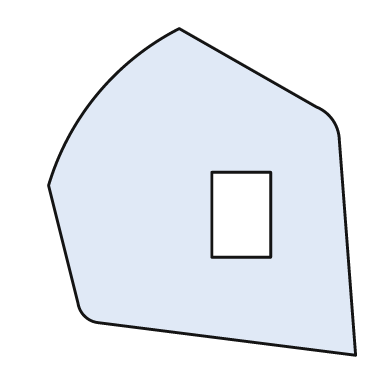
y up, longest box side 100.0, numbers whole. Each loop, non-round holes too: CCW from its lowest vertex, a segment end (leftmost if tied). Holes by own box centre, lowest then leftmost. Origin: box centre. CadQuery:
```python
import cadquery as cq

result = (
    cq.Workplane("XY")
    .moveTo(47.0, -50.0)
    .lineTo(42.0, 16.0)
    .threePointArc((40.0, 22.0), (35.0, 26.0))
    .lineTo(-7.0, 50.0)
    .threePointArc((-32.0, 30.0), (-47.0, 2.0))
    .lineTo(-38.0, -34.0)
    .threePointArc((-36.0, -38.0), (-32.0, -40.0))
    .close()
    .moveTo(3.0, -20.0)
    .lineTo(21.0, -20.0)
    .lineTo(21.0, 6.0)
    .lineTo(3.0, 6.0)
    .close()
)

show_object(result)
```